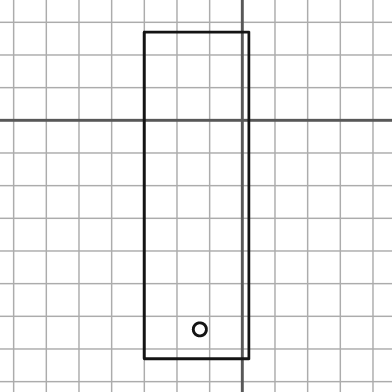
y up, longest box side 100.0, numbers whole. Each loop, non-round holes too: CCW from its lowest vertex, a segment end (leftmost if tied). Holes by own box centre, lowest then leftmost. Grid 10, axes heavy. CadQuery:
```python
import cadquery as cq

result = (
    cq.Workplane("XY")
    .moveTo(-30.0, -73.0)
    .lineTo(2.0, -73.0)
    .lineTo(2.0, 27.0)
    .lineTo(-30.0, 27.0)
    .close()
    .moveTo(-13.0, -64.0)
    .circle(2.0)
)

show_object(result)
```